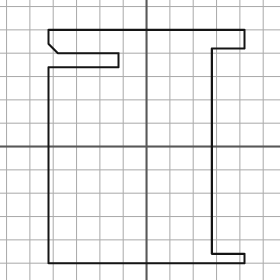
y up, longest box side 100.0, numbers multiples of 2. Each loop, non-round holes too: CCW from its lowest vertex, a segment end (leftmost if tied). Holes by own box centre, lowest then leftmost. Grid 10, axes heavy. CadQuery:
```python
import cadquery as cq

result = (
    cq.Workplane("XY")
    .moveTo(-42.0, -50.0)
    .lineTo(42.0, -50.0)
    .lineTo(42.0, -46.0)
    .lineTo(28.0, -46.0)
    .lineTo(28.0, 42.0)
    .lineTo(42.0, 42.0)
    .lineTo(42.0, 50.0)
    .lineTo(-42.0, 50.0)
    .lineTo(-42.0, 44.0)
    .lineTo(-38.0, 40.0)
    .lineTo(-12.0, 40.0)
    .lineTo(-12.0, 34.0)
    .lineTo(-42.0, 34.0)
    .close()
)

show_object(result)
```